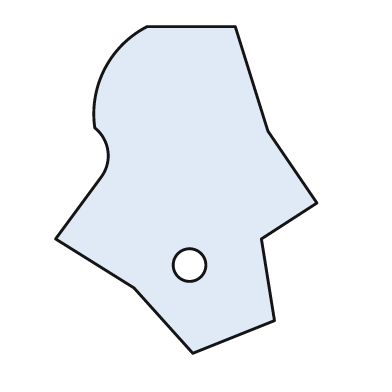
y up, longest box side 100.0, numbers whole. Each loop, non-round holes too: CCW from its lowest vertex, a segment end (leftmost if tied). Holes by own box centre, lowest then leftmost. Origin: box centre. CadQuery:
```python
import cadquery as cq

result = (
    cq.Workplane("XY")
    .moveTo(2.0, -50.0)
    .lineTo(27.0, -40.0)
    .lineTo(23.0, -15.0)
    .lineTo(40.0, -4.0)
    .lineTo(25.0, 18.0)
    .lineTo(15.0, 50.0)
    .lineTo(-12.0, 50.0)
    .threePointArc((-25.0, 37.0), (-28.0, 19.0))
    .threePointArc((-24.0, 12.0), (-26.0, 4.0))
    .lineTo(-40.0, -15.0)
    .lineTo(-16.0, -30.0)
    .close()
    .moveTo(1.0, -23.0)
    .circle(5.0)
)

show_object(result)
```